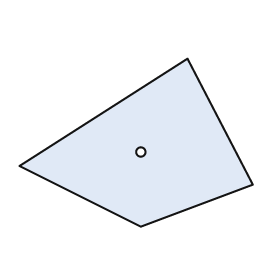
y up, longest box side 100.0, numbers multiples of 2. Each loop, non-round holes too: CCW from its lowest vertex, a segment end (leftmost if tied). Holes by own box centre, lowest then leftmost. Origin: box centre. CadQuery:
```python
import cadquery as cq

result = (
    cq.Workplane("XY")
    .moveTo(2.0, -36.0)
    .lineTo(50.0, -18.0)
    .lineTo(22.0, 36.0)
    .lineTo(-50.0, -10.0)
    .close()
    .moveTo(2.0, -4.0)
    .circle(2.0)
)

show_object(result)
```